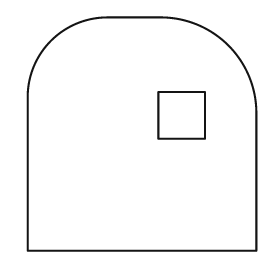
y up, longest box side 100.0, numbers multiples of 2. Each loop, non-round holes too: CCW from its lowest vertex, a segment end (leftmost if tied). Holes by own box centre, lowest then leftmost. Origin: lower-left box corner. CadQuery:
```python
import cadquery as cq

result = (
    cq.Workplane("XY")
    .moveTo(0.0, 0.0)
    .lineTo(98.0, 0.0)
    .lineTo(98.0, 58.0)
    .threePointArc((86.0, 88.0), (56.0, 100.0))
    .lineTo(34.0, 100.0)
    .threePointArc((10.0, 90.0), (0.0, 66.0))
    .close()
    .moveTo(56.0, 48.0)
    .lineTo(76.0, 48.0)
    .lineTo(76.0, 68.0)
    .lineTo(56.0, 68.0)
    .close()
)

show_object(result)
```